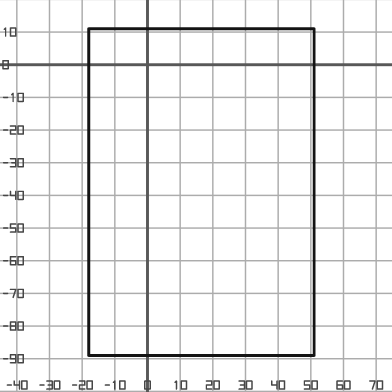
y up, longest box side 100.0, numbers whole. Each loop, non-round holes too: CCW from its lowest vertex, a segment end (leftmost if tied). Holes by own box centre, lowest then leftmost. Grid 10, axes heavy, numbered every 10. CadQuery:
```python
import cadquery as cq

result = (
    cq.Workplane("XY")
    .moveTo(-18.0, -89.0)
    .lineTo(51.0, -89.0)
    .lineTo(51.0, 11.0)
    .lineTo(-18.0, 11.0)
    .close()
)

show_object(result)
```